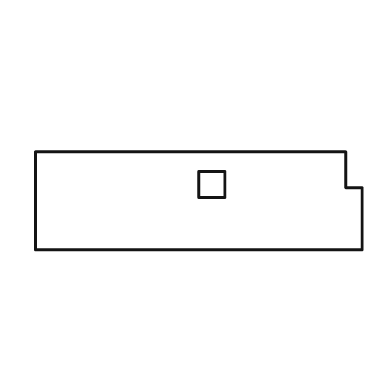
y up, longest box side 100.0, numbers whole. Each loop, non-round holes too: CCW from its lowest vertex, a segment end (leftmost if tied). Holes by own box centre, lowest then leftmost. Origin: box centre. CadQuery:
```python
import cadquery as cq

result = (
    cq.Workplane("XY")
    .moveTo(-50.0, -15.0)
    .lineTo(50.0, -15.0)
    .lineTo(50.0, 4.0)
    .lineTo(45.0, 4.0)
    .lineTo(45.0, 15.0)
    .lineTo(-50.0, 15.0)
    .close()
    .moveTo(0.0, 1.0)
    .lineTo(8.0, 1.0)
    .lineTo(8.0, 9.0)
    .lineTo(0.0, 9.0)
    .close()
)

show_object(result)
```